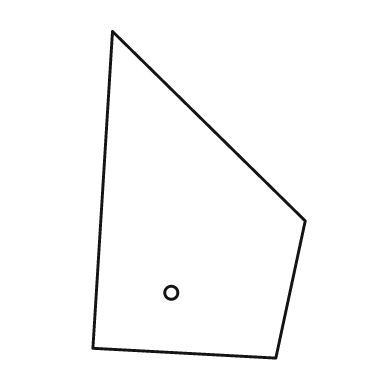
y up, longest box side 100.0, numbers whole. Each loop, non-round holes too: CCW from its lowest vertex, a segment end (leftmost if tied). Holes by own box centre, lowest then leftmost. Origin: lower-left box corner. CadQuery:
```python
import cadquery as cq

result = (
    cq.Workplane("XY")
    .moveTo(56.0, 0.0)
    .lineTo(65.0, 42.0)
    .lineTo(6.0, 100.0)
    .lineTo(0.0, 3.0)
    .close()
    .moveTo(24.0, 20.0)
    .circle(2.0)
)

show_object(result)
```